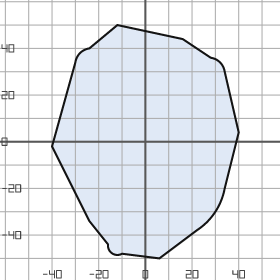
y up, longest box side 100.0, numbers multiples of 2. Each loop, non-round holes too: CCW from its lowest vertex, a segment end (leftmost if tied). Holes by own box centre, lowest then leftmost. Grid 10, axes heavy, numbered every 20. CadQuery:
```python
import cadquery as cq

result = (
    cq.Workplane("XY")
    .moveTo(6.0, -50.0)
    .lineTo(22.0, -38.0)
    .threePointArc((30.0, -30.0), (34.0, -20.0))
    .lineTo(40.0, 4.0)
    .lineTo(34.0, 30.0)
    .threePointArc((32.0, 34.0), (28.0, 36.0))
    .lineTo(16.0, 44.0)
    .lineTo(-12.0, 50.0)
    .lineTo(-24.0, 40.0)
    .threePointArc((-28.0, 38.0), (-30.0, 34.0))
    .lineTo(-40.0, -2.0)
    .lineTo(-24.0, -34.0)
    .lineTo(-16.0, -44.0)
    .threePointArc((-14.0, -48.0), (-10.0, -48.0))
    .close()
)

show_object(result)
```